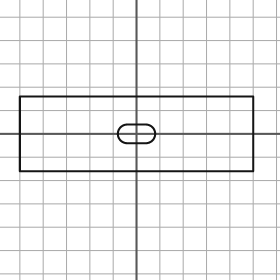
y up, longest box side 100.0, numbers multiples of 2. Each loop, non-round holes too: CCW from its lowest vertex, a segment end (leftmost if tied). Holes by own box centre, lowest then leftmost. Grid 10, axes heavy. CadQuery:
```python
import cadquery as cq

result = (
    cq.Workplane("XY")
    .moveTo(-50.0, -16.0)
    .lineTo(50.0, -16.0)
    .lineTo(50.0, 16.0)
    .lineTo(-50.0, 16.0)
    .close()
    .moveTo(-4.0, -4.0)
    .lineTo(4.0, -4.0)
    .threePointArc((8.0, 0.0), (4.0, 4.0))
    .lineTo(-4.0, 4.0)
    .threePointArc((-8.0, 0.0), (-4.0, -4.0))
    .close()
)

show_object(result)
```